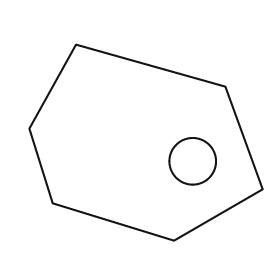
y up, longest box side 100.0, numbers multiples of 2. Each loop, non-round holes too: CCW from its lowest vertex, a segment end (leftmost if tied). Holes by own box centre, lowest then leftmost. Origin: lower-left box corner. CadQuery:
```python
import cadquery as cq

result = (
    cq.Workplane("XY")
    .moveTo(62.0, 0.0)
    .lineTo(100.0, 22.0)
    .lineTo(84.0, 66.0)
    .lineTo(20.0, 84.0)
    .lineTo(0.0, 48.0)
    .lineTo(10.0, 16.0)
    .close()
    .moveTo(70.0, 34.0)
    .circle(10.0)
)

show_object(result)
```